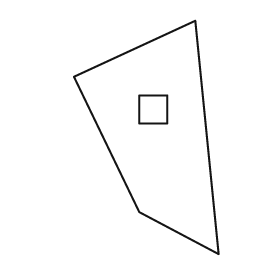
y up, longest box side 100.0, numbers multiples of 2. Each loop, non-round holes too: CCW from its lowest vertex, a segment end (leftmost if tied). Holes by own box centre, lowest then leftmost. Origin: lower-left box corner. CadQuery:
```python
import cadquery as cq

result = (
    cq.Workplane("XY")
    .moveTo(62.0, 0.0)
    .lineTo(52.0, 100.0)
    .lineTo(0.0, 76.0)
    .lineTo(28.0, 18.0)
    .close()
    .moveTo(28.0, 56.0)
    .lineTo(40.0, 56.0)
    .lineTo(40.0, 68.0)
    .lineTo(28.0, 68.0)
    .close()
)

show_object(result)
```